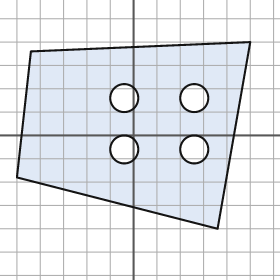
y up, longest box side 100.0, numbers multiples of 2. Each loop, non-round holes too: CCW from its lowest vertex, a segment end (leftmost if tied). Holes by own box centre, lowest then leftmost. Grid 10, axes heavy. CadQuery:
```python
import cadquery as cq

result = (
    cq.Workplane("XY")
    .moveTo(36.0, -40.0)
    .lineTo(50.0, 40.0)
    .lineTo(-44.0, 36.0)
    .lineTo(-50.0, -18.0)
    .close()
    .moveTo(-4.0, -6.0)
    .circle(6.0)
    .moveTo(26.0, -6.0)
    .circle(6.0)
    .moveTo(-4.0, 16.0)
    .circle(6.0)
    .moveTo(26.0, 16.0)
    .circle(6.0)
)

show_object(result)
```